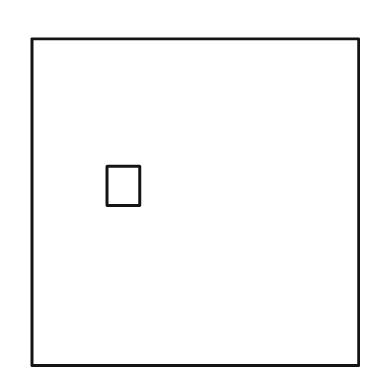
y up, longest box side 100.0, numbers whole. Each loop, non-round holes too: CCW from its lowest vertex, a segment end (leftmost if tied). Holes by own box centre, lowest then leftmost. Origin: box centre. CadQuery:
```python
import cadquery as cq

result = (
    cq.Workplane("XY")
    .moveTo(-50.0, -50.0)
    .lineTo(50.0, -50.0)
    .lineTo(50.0, 50.0)
    .lineTo(-50.0, 50.0)
    .close()
    .moveTo(-27.0, -1.0)
    .lineTo(-17.0, -1.0)
    .lineTo(-17.0, 11.0)
    .lineTo(-27.0, 11.0)
    .close()
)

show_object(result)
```